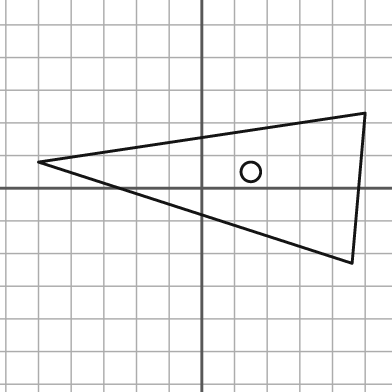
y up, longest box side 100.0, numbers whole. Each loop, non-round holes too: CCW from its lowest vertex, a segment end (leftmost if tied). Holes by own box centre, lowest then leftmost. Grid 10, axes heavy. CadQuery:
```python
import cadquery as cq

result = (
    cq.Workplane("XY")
    .moveTo(46.0, -23.0)
    .lineTo(50.0, 23.0)
    .lineTo(-50.0, 8.0)
    .close()
    .moveTo(15.0, 5.0)
    .circle(3.0)
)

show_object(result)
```